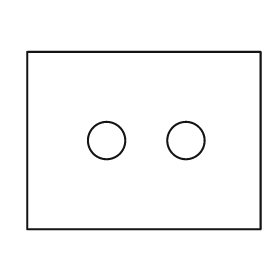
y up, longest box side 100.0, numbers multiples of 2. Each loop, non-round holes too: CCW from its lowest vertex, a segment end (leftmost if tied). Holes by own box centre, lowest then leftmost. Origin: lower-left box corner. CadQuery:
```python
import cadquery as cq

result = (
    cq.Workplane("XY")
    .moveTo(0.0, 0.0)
    .lineTo(100.0, 0.0)
    .lineTo(100.0, 76.0)
    .lineTo(0.0, 76.0)
    .close()
    .moveTo(34.0, 38.0)
    .circle(8.0)
    .moveTo(68.0, 38.0)
    .circle(8.0)
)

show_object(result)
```